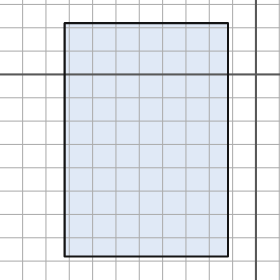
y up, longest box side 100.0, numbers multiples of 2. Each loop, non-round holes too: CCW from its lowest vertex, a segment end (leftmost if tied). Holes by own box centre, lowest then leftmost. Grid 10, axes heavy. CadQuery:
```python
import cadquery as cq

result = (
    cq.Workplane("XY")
    .moveTo(-82.0, -78.0)
    .lineTo(-12.0, -78.0)
    .lineTo(-12.0, 22.0)
    .lineTo(-82.0, 22.0)
    .close()
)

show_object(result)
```